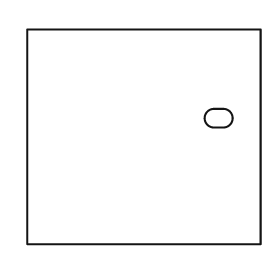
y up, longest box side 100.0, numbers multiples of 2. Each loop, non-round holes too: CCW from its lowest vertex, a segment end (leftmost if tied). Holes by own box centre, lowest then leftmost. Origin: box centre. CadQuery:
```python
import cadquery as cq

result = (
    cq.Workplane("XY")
    .moveTo(-50.0, -46.0)
    .lineTo(50.0, -46.0)
    .lineTo(50.0, 46.0)
    .lineTo(-50.0, 46.0)
    .close()
    .moveTo(30.0, 4.0)
    .lineTo(34.0, 4.0)
    .threePointArc((38.0, 8.0), (34.0, 12.0))
    .lineTo(30.0, 12.0)
    .threePointArc((26.0, 8.0), (30.0, 4.0))
    .close()
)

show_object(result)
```